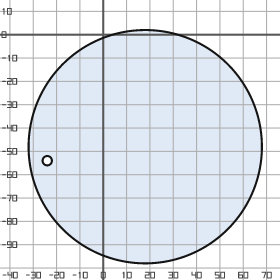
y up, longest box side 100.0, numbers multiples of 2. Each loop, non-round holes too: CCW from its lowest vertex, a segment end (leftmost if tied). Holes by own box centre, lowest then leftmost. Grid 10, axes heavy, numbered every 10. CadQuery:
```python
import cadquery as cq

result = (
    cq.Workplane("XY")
    .moveTo(18.0, -48.0)
    .circle(50.0)
    .moveTo(-24.0, -54.0)
    .circle(2.0)
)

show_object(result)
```